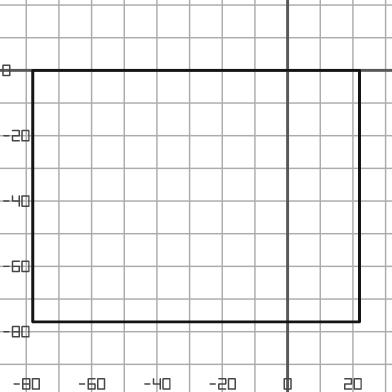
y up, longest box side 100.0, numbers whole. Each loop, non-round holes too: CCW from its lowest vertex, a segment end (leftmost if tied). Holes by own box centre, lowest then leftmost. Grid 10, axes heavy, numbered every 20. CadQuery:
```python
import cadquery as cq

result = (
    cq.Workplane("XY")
    .moveTo(-78.0, -77.0)
    .lineTo(22.0, -77.0)
    .lineTo(22.0, 0.0)
    .lineTo(-78.0, 0.0)
    .close()
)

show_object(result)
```